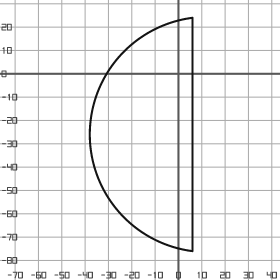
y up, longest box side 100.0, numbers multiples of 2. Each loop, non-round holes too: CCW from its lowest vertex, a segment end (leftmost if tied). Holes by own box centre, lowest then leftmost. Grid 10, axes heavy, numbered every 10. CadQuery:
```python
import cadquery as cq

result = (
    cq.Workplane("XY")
    .moveTo(6.0, -76.0)
    .lineTo(6.0, 24.0)
    .threePointArc((-38.0, -26.0), (6.0, -76.0))
    .close()
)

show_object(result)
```